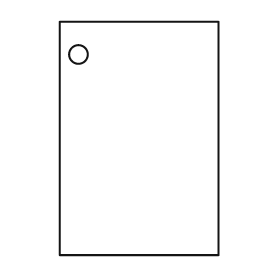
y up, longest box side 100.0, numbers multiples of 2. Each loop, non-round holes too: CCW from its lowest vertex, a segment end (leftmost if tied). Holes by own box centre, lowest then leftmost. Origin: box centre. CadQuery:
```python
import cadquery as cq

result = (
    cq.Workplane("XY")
    .moveTo(-34.0, -50.0)
    .lineTo(34.0, -50.0)
    .lineTo(34.0, 50.0)
    .lineTo(-34.0, 50.0)
    .close()
    .moveTo(-26.0, 36.0)
    .circle(4.0)
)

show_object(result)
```